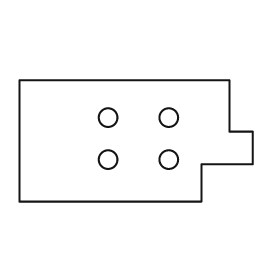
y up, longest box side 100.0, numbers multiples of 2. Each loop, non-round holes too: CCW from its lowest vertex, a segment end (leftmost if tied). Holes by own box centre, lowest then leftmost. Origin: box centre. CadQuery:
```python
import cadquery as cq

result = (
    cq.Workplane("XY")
    .moveTo(-50.0, -26.0)
    .lineTo(28.0, -26.0)
    .lineTo(28.0, -10.0)
    .lineTo(50.0, -10.0)
    .lineTo(50.0, 4.0)
    .lineTo(40.0, 4.0)
    .lineTo(40.0, 26.0)
    .lineTo(-50.0, 26.0)
    .close()
    .moveTo(-12.0, -8.0)
    .circle(4.0)
    .moveTo(14.0, -8.0)
    .circle(4.0)
    .moveTo(-12.0, 10.0)
    .circle(4.0)
    .moveTo(14.0, 10.0)
    .circle(4.0)
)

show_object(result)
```